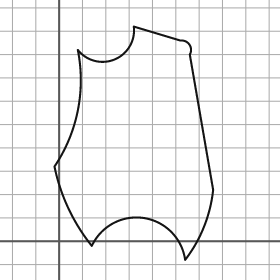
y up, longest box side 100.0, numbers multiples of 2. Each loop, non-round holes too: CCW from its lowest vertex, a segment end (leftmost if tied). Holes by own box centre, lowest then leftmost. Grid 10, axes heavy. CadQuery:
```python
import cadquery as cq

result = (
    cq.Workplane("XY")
    .moveTo(54.0, -8.0)
    .threePointArc((62.0, 6.0), (66.0, 22.0))
    .lineTo(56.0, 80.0)
    .threePointArc((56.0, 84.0), (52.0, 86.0))
    .lineTo(32.0, 92.0)
    .threePointArc((24.0, 78.0), (8.0, 82.0))
    .threePointArc((8.0, 56.0), (-2.0, 32.0))
    .threePointArc((4.0, 14.0), (14.0, -2.0))
    .threePointArc((36.0, 10.0), (54.0, -8.0))
    .close()
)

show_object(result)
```